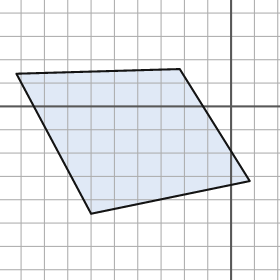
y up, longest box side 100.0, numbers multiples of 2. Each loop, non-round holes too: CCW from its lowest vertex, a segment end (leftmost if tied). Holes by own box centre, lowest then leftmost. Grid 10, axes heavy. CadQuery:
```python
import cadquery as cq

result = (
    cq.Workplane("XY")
    .moveTo(-60.0, -46.0)
    .lineTo(8.0, -32.0)
    .lineTo(-22.0, 16.0)
    .lineTo(-92.0, 14.0)
    .close()
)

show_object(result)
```